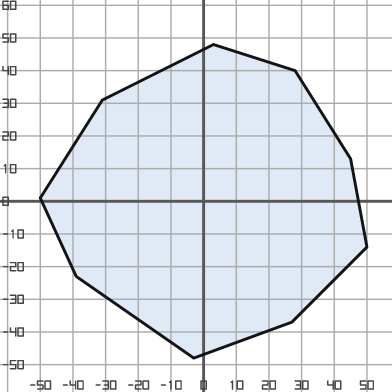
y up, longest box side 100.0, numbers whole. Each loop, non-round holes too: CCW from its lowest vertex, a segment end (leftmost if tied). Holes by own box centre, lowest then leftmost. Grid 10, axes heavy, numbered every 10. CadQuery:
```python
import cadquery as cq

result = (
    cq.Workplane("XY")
    .moveTo(-3.0, -48.0)
    .lineTo(27.0, -37.0)
    .lineTo(50.0, -14.0)
    .lineTo(45.0, 13.0)
    .lineTo(28.0, 40.0)
    .lineTo(3.0, 48.0)
    .lineTo(-31.0, 31.0)
    .lineTo(-50.0, 1.0)
    .lineTo(-39.0, -23.0)
    .close()
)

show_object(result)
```